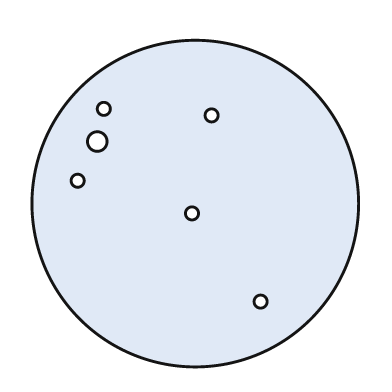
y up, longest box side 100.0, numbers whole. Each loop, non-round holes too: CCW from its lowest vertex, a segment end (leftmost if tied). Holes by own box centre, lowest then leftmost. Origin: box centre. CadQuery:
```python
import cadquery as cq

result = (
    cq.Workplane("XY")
    .moveTo(0.0, 0.0)
    .circle(50.0)
    .moveTo(20.0, -30.0)
    .circle(2.0)
    .moveTo(-1.0, -3.0)
    .circle(2.0)
    .moveTo(-36.0, 7.0)
    .circle(2.0)
    .moveTo(-30.0, 19.0)
    .circle(3.0)
    .moveTo(5.0, 27.0)
    .circle(2.0)
    .moveTo(-28.0, 29.0)
    .circle(2.0)
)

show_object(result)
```